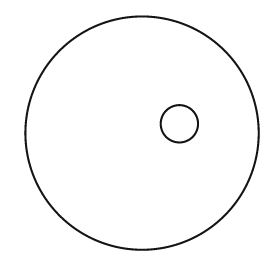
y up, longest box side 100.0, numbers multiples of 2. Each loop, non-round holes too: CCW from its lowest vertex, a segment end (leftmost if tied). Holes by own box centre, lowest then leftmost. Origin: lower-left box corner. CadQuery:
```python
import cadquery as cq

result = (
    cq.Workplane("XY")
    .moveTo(50.0, 50.0)
    .circle(50.0)
    .moveTo(66.0, 54.0)
    .circle(8.0)
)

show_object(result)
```